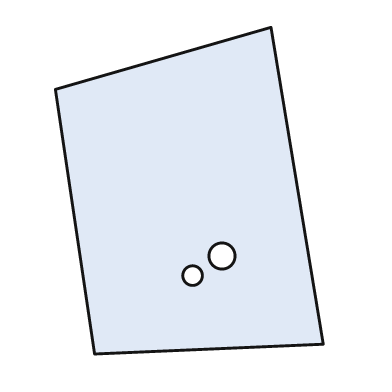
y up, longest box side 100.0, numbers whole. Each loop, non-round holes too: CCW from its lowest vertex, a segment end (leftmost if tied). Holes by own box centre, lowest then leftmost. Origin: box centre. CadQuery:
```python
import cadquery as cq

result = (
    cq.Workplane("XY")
    .moveTo(-29.0, -50.0)
    .lineTo(41.0, -47.0)
    .lineTo(25.0, 50.0)
    .lineTo(-41.0, 31.0)
    .close()
    .moveTo(1.0, -26.0)
    .circle(3.0)
    .moveTo(10.0, -20.0)
    .circle(4.0)
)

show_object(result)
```